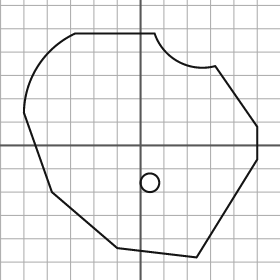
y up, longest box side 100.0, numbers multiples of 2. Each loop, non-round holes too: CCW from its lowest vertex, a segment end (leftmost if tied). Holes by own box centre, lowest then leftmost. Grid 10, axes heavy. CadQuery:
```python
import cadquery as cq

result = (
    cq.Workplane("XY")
    .moveTo(24.0, -48.0)
    .lineTo(50.0, -6.0)
    .lineTo(50.0, 8.0)
    .lineTo(32.0, 34.0)
    .threePointArc((16.0, 36.0), (6.0, 48.0))
    .lineTo(-28.0, 48.0)
    .threePointArc((-44.0, 34.0), (-50.0, 14.0))
    .lineTo(-38.0, -20.0)
    .lineTo(-10.0, -44.0)
    .close()
    .moveTo(4.0, -16.0)
    .circle(4.0)
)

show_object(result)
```